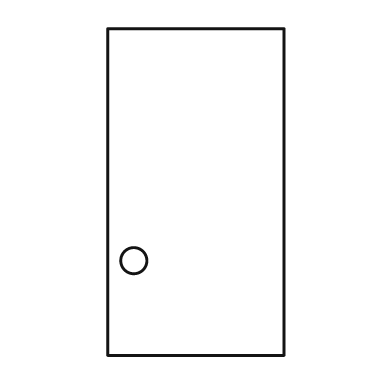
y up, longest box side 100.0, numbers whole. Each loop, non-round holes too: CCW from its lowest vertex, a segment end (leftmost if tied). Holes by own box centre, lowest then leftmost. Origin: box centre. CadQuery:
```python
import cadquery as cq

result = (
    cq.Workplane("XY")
    .moveTo(-27.0, -50.0)
    .lineTo(27.0, -50.0)
    .lineTo(27.0, 50.0)
    .lineTo(-27.0, 50.0)
    .close()
    .moveTo(-19.0, -21.0)
    .circle(4.0)
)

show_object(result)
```